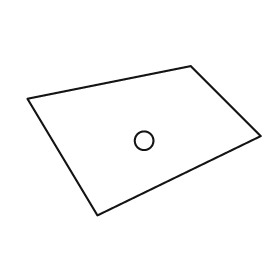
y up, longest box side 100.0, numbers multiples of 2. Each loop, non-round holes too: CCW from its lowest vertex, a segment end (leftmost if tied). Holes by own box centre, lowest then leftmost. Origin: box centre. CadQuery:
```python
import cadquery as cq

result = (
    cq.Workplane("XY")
    .moveTo(-20.0, -32.0)
    .lineTo(50.0, 2.0)
    .lineTo(20.0, 32.0)
    .lineTo(-50.0, 18.0)
    .close()
    .moveTo(0.0, 0.0)
    .circle(4.0)
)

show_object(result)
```